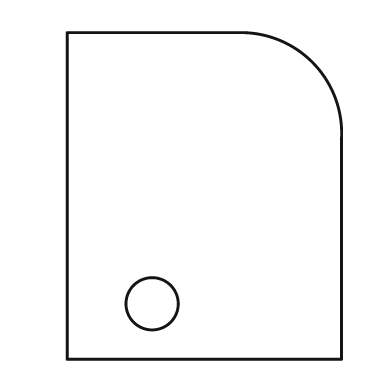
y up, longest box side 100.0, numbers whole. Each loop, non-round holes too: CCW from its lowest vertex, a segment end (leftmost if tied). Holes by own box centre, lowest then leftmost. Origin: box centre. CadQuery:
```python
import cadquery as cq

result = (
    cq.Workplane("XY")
    .moveTo(-42.0, -50.0)
    .lineTo(42.0, -50.0)
    .lineTo(42.0, 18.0)
    .threePointArc((33.0, 41.0), (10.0, 50.0))
    .lineTo(-42.0, 50.0)
    .close()
    .moveTo(-16.0, -33.0)
    .circle(8.0)
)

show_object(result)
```